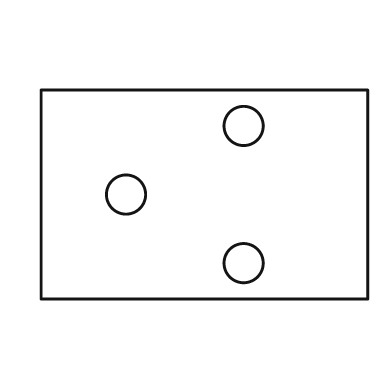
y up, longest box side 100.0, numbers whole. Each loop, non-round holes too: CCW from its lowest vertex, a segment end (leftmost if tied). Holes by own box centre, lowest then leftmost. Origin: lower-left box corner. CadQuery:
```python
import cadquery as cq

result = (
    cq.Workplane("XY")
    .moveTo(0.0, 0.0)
    .lineTo(100.0, 0.0)
    .lineTo(100.0, 64.0)
    .lineTo(0.0, 64.0)
    .close()
    .moveTo(62.0, 11.0)
    .circle(6.0)
    .moveTo(26.0, 32.0)
    .circle(6.0)
    .moveTo(62.0, 53.0)
    .circle(6.0)
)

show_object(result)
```